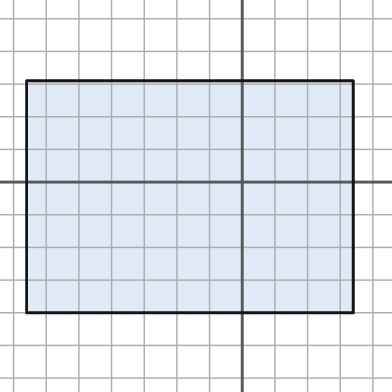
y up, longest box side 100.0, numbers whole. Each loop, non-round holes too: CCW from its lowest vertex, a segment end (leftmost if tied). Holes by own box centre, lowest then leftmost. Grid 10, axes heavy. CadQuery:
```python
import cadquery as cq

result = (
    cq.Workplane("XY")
    .moveTo(-66.0, -40.0)
    .lineTo(34.0, -40.0)
    .lineTo(34.0, 31.0)
    .lineTo(-66.0, 31.0)
    .close()
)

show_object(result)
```